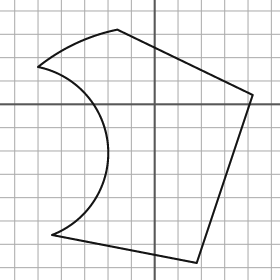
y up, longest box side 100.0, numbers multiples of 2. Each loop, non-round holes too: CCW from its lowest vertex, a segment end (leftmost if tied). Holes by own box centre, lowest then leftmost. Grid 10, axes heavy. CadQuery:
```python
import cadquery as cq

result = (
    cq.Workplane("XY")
    .moveTo(18.0, -68.0)
    .lineTo(42.0, 4.0)
    .lineTo(-16.0, 32.0)
    .threePointArc((-34.0, 26.0), (-50.0, 16.0))
    .threePointArc((-20.0, -18.0), (-44.0, -56.0))
    .close()
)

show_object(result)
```